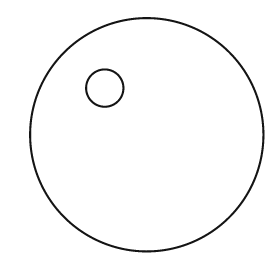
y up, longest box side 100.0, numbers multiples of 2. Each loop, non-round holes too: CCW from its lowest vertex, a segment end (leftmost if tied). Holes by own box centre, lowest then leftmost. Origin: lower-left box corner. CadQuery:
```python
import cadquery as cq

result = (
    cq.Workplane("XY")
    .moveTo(50.0, 50.0)
    .circle(50.0)
    .moveTo(32.0, 70.0)
    .circle(8.0)
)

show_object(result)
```